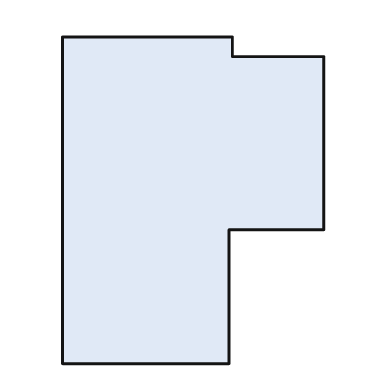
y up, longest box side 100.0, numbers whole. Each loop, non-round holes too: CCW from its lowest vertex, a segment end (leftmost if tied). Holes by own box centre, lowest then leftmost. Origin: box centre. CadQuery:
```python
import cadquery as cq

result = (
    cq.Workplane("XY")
    .moveTo(-40.0, -50.0)
    .lineTo(11.0, -50.0)
    .lineTo(11.0, -9.0)
    .lineTo(40.0, -9.0)
    .lineTo(40.0, 44.0)
    .lineTo(12.0, 44.0)
    .lineTo(12.0, 50.0)
    .lineTo(-40.0, 50.0)
    .close()
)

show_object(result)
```